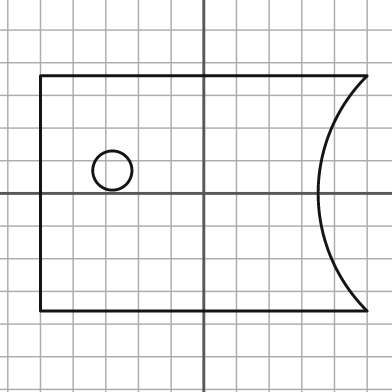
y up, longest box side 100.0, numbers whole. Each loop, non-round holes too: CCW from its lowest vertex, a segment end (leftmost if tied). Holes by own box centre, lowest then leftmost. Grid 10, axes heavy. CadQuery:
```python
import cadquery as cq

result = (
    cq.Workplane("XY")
    .moveTo(-50.0, -36.0)
    .lineTo(50.0, -36.0)
    .threePointArc((35.0, 0.0), (50.0, 36.0))
    .lineTo(-50.0, 36.0)
    .close()
    .moveTo(-28.0, 7.0)
    .circle(6.0)
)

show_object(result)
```